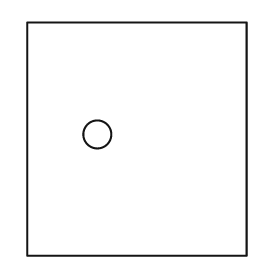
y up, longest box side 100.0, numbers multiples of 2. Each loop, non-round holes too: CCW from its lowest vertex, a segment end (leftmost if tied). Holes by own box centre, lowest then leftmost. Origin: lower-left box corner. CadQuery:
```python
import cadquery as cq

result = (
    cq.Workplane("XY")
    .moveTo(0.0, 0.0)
    .lineTo(94.0, 0.0)
    .lineTo(94.0, 100.0)
    .lineTo(0.0, 100.0)
    .close()
    .moveTo(30.0, 52.0)
    .circle(6.0)
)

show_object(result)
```